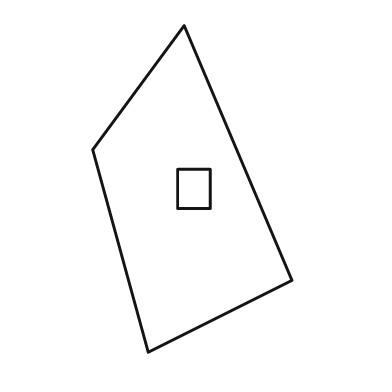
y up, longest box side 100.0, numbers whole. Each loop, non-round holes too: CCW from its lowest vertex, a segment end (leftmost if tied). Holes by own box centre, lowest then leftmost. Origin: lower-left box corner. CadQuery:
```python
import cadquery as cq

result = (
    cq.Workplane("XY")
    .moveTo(17.0, 0.0)
    .lineTo(61.0, 22.0)
    .lineTo(28.0, 100.0)
    .lineTo(0.0, 62.0)
    .close()
    .moveTo(26.0, 44.0)
    .lineTo(36.0, 44.0)
    .lineTo(36.0, 56.0)
    .lineTo(26.0, 56.0)
    .close()
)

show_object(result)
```